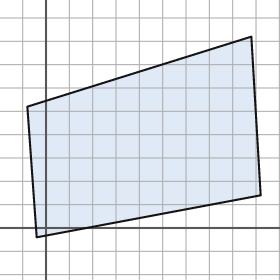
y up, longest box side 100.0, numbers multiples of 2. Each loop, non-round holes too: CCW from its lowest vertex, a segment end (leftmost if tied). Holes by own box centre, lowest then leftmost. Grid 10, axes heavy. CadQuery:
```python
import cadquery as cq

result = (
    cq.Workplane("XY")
    .moveTo(-4.0, -4.0)
    .lineTo(92.0, 14.0)
    .lineTo(88.0, 82.0)
    .lineTo(-8.0, 52.0)
    .close()
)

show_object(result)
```